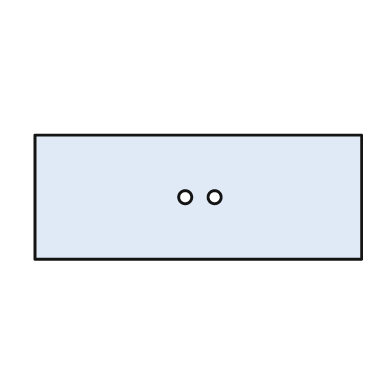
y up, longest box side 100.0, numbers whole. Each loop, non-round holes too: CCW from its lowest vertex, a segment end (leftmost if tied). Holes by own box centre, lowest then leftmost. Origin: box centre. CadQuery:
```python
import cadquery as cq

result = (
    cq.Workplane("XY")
    .moveTo(-50.0, -19.0)
    .lineTo(50.0, -19.0)
    .lineTo(50.0, 19.0)
    .lineTo(-50.0, 19.0)
    .close()
    .moveTo(-4.0, 0.0)
    .circle(2.0)
    .moveTo(5.0, 0.0)
    .circle(2.0)
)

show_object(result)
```